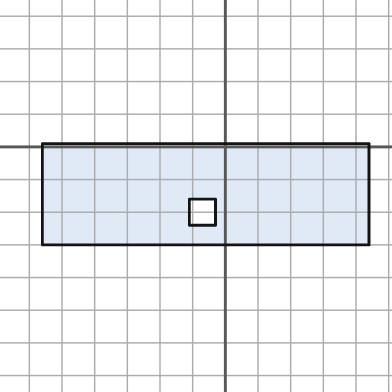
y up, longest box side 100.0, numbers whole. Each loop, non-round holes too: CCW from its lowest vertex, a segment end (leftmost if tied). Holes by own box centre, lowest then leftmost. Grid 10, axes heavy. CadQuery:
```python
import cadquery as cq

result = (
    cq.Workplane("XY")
    .moveTo(-56.0, -30.0)
    .lineTo(44.0, -30.0)
    .lineTo(44.0, 1.0)
    .lineTo(-56.0, 1.0)
    .close()
    .moveTo(-11.0, -24.0)
    .lineTo(-3.0, -24.0)
    .lineTo(-3.0, -16.0)
    .lineTo(-11.0, -16.0)
    .close()
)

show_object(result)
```